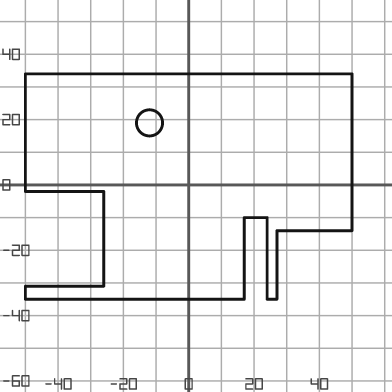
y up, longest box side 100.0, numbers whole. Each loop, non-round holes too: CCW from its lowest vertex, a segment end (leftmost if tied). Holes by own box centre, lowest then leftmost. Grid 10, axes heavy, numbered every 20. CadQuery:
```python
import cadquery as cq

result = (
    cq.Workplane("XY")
    .moveTo(-50.0, -35.0)
    .lineTo(17.0, -35.0)
    .lineTo(17.0, -10.0)
    .lineTo(24.0, -10.0)
    .lineTo(24.0, -35.0)
    .lineTo(27.0, -35.0)
    .lineTo(27.0, -14.0)
    .lineTo(50.0, -14.0)
    .lineTo(50.0, 34.0)
    .lineTo(-50.0, 34.0)
    .lineTo(-50.0, -2.0)
    .lineTo(-26.0, -2.0)
    .lineTo(-26.0, -31.0)
    .lineTo(-50.0, -31.0)
    .close()
    .moveTo(-12.0, 19.0)
    .circle(4.0)
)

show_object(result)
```